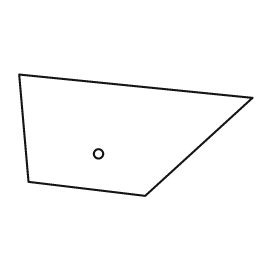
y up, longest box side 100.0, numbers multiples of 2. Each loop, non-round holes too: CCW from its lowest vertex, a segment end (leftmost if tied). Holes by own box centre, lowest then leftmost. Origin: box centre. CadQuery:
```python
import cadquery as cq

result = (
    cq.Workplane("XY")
    .moveTo(4.0, -26.0)
    .lineTo(50.0, 16.0)
    .lineTo(-50.0, 26.0)
    .lineTo(-46.0, -20.0)
    .close()
    .moveTo(-16.0, -8.0)
    .circle(2.0)
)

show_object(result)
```